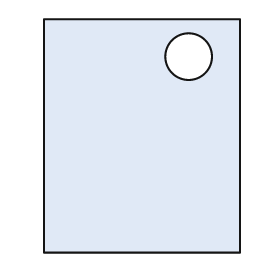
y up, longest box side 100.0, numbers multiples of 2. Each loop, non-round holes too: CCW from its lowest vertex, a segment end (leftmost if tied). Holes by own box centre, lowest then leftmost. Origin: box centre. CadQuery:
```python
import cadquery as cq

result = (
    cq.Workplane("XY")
    .moveTo(-42.0, -50.0)
    .lineTo(42.0, -50.0)
    .lineTo(42.0, 50.0)
    .lineTo(-42.0, 50.0)
    .close()
    .moveTo(20.0, 34.0)
    .circle(10.0)
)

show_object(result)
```